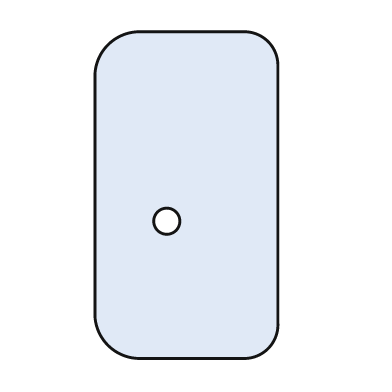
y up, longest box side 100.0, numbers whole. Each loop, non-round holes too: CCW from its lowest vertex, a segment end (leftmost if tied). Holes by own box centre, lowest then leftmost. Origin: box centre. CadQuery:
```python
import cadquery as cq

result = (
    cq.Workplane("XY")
    .moveTo(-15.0, -50.0)
    .lineTo(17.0, -50.0)
    .threePointArc((25.0, -47.0), (28.0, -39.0))
    .lineTo(28.0, 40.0)
    .threePointArc((25.0, 47.0), (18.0, 50.0))
    .lineTo(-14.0, 50.0)
    .threePointArc((-24.0, 46.0), (-28.0, 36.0))
    .lineTo(-28.0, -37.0)
    .threePointArc((-24.0, -46.0), (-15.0, -50.0))
    .close()
    .moveTo(-6.0, -8.0)
    .circle(4.0)
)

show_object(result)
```